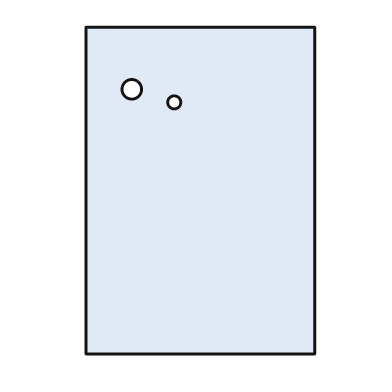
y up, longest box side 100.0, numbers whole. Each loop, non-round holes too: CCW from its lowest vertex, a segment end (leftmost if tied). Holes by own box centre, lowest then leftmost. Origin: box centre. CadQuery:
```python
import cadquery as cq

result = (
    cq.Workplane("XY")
    .moveTo(-35.0, -50.0)
    .lineTo(35.0, -50.0)
    .lineTo(35.0, 50.0)
    .lineTo(-35.0, 50.0)
    .close()
    .moveTo(-8.0, 27.0)
    .circle(2.0)
    .moveTo(-21.0, 31.0)
    .circle(3.0)
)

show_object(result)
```